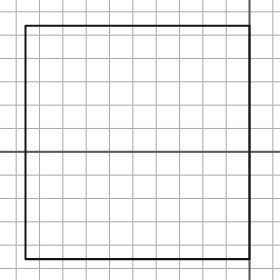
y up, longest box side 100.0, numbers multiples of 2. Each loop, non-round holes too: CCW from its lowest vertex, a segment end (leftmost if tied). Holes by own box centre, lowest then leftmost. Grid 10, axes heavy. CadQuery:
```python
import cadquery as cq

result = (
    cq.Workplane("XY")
    .moveTo(-96.0, -46.0)
    .lineTo(0.0, -46.0)
    .lineTo(0.0, 54.0)
    .lineTo(-96.0, 54.0)
    .close()
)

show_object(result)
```